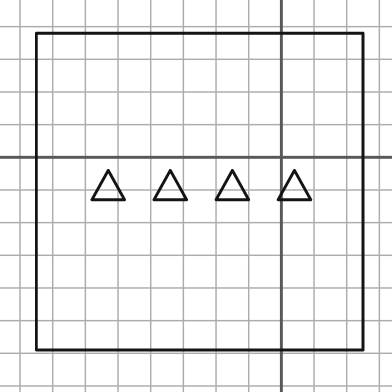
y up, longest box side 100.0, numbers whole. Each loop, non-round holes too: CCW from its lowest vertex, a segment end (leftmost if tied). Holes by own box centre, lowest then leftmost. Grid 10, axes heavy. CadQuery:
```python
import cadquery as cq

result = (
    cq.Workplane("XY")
    .moveTo(-75.0, -59.0)
    .lineTo(25.0, -59.0)
    .lineTo(25.0, 38.0)
    .lineTo(-75.0, 38.0)
    .close()
    .moveTo(-58.0, -13.0)
    .lineTo(-48.0, -13.0)
    .lineTo(-53.0, -4.0)
    .close()
    .moveTo(-39.0, -13.0)
    .lineTo(-29.0, -13.0)
    .lineTo(-34.0, -4.0)
    .close()
    .moveTo(-20.0, -13.0)
    .lineTo(-10.0, -13.0)
    .lineTo(-15.0, -4.0)
    .close()
    .moveTo(-1.0, -13.0)
    .lineTo(9.0, -13.0)
    .lineTo(4.0, -4.0)
    .close()
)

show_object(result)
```